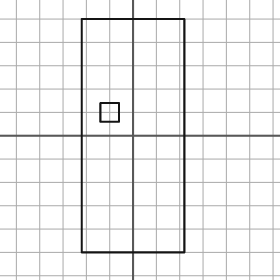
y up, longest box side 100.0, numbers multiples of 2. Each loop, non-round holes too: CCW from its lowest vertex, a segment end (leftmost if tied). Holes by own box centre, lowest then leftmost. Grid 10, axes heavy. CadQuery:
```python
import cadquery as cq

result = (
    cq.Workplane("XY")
    .moveTo(-22.0, -50.0)
    .lineTo(22.0, -50.0)
    .lineTo(22.0, 50.0)
    .lineTo(-22.0, 50.0)
    .close()
    .moveTo(-14.0, 6.0)
    .lineTo(-6.0, 6.0)
    .lineTo(-6.0, 14.0)
    .lineTo(-14.0, 14.0)
    .close()
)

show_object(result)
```